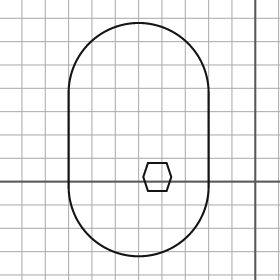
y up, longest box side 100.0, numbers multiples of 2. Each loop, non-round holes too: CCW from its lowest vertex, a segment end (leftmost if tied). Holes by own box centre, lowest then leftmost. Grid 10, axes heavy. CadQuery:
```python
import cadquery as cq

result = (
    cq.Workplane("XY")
    .moveTo(-80.0, -2.0)
    .threePointArc((-50.0, -32.0), (-20.0, -2.0))
    .lineTo(-20.0, 38.0)
    .threePointArc((-50.0, 68.0), (-80.0, 38.0))
    .close()
    .moveTo(-46.0, -4.0)
    .lineTo(-38.0, -4.0)
    .lineTo(-36.0, 2.0)
    .lineTo(-38.0, 8.0)
    .lineTo(-46.0, 8.0)
    .lineTo(-48.0, 2.0)
    .close()
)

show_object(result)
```